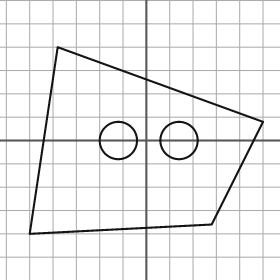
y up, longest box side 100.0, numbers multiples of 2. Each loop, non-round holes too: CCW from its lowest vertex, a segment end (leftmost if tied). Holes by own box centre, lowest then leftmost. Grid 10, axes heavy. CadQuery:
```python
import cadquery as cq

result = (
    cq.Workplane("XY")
    .moveTo(-50.0, -40.0)
    .lineTo(28.0, -36.0)
    .lineTo(50.0, 8.0)
    .lineTo(-38.0, 40.0)
    .close()
    .moveTo(-12.0, 0.0)
    .circle(8.0)
    .moveTo(14.0, 0.0)
    .circle(8.0)
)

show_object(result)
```